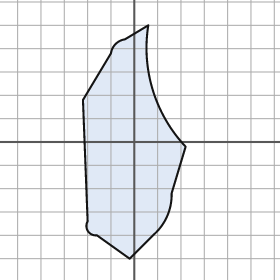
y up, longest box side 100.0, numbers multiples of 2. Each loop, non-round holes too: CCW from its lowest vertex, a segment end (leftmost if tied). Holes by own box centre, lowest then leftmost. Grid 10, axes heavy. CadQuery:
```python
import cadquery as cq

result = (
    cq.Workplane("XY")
    .moveTo(-2.0, -50.0)
    .lineTo(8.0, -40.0)
    .threePointArc((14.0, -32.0), (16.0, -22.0))
    .lineTo(22.0, -2.0)
    .threePointArc((8.0, 22.0), (6.0, 50.0))
    .lineTo(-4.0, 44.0)
    .threePointArc((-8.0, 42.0), (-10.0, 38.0))
    .lineTo(-22.0, 18.0)
    .lineTo(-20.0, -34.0)
    .threePointArc((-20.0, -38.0), (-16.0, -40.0))
    .close()
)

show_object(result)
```